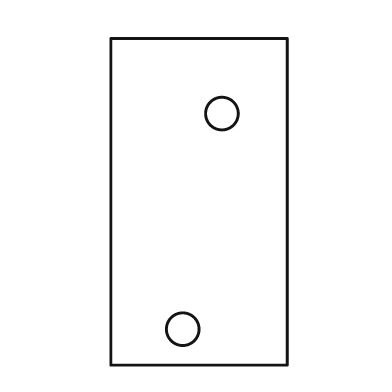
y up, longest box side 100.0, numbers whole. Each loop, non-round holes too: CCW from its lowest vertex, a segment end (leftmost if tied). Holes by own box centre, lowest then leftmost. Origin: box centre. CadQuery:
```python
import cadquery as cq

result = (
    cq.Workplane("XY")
    .moveTo(-27.0, -50.0)
    .lineTo(27.0, -50.0)
    .lineTo(27.0, 50.0)
    .lineTo(-27.0, 50.0)
    .close()
    .moveTo(-5.0, -39.0)
    .circle(5.0)
    .moveTo(7.0, 27.0)
    .circle(5.0)
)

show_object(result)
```